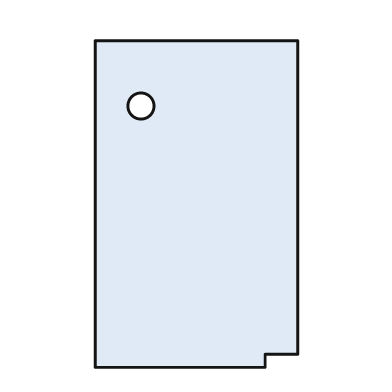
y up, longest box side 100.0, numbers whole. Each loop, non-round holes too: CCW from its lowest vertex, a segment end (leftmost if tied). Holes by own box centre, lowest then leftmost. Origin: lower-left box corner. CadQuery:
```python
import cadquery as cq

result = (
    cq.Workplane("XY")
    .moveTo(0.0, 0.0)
    .lineTo(52.0, 0.0)
    .lineTo(52.0, 4.0)
    .lineTo(62.0, 4.0)
    .lineTo(62.0, 100.0)
    .lineTo(0.0, 100.0)
    .close()
    .moveTo(14.0, 80.0)
    .circle(4.0)
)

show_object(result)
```